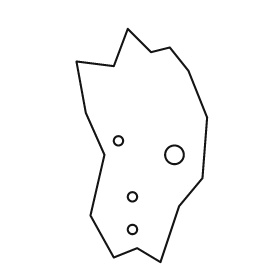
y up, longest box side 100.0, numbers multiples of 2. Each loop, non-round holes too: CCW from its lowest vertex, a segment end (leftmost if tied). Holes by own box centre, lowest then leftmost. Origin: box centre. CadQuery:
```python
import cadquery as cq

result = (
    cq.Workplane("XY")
    .moveTo(8.0, -50.0)
    .lineTo(16.0, -26.0)
    .lineTo(26.0, -14.0)
    .lineTo(28.0, 12.0)
    .lineTo(20.0, 32.0)
    .lineTo(12.0, 42.0)
    .lineTo(4.0, 40.0)
    .lineTo(-6.0, 50.0)
    .lineTo(-12.0, 34.0)
    .lineTo(-28.0, 36.0)
    .lineTo(-24.0, 14.0)
    .lineTo(-16.0, -4.0)
    .lineTo(-22.0, -30.0)
    .lineTo(-12.0, -48.0)
    .lineTo(-2.0, -44.0)
    .close()
    .moveTo(-4.0, -36.0)
    .circle(2.0)
    .moveTo(-4.0, -22.0)
    .circle(2.0)
    .moveTo(14.0, -4.0)
    .circle(4.0)
    .moveTo(-10.0, 2.0)
    .circle(2.0)
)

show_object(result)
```